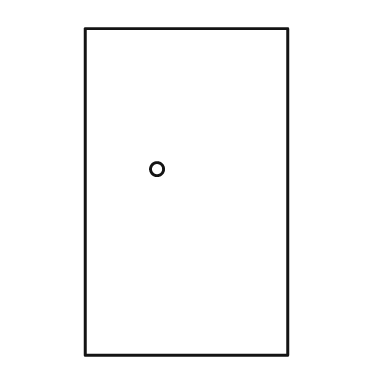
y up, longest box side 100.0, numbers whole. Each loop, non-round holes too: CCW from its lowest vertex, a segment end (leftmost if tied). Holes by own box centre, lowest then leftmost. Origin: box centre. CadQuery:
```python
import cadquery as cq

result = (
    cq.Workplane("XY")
    .moveTo(-31.0, -50.0)
    .lineTo(31.0, -50.0)
    .lineTo(31.0, 50.0)
    .lineTo(-31.0, 50.0)
    .close()
    .moveTo(-9.0, 7.0)
    .circle(2.0)
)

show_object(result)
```